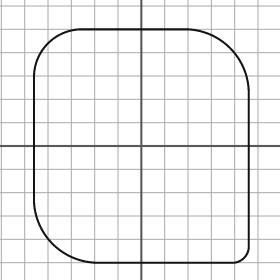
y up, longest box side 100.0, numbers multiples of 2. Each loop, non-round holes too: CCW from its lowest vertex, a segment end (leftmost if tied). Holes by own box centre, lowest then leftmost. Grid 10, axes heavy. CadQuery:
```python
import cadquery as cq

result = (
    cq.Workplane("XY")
    .moveTo(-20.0, -50.0)
    .lineTo(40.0, -50.0)
    .threePointArc((44.0, -48.0), (46.0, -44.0))
    .lineTo(46.0, 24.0)
    .threePointArc((38.0, 42.0), (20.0, 50.0))
    .lineTo(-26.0, 50.0)
    .threePointArc((-40.0, 44.0), (-46.0, 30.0))
    .lineTo(-46.0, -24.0)
    .threePointArc((-38.0, -42.0), (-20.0, -50.0))
    .close()
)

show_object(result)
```